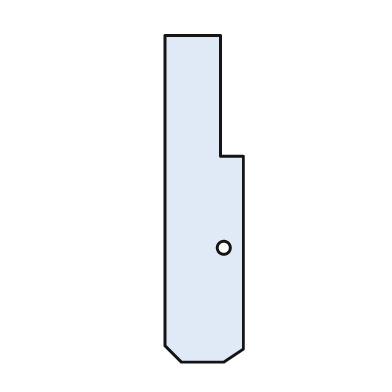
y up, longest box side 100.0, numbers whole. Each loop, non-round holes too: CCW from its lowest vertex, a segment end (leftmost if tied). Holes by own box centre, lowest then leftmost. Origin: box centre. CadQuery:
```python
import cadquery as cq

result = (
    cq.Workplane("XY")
    .moveTo(-7.0, -50.0)
    .lineTo(6.0, -50.0)
    .lineTo(12.0, -46.0)
    .lineTo(12.0, 13.0)
    .lineTo(5.0, 13.0)
    .lineTo(5.0, 50.0)
    .lineTo(-12.0, 50.0)
    .lineTo(-12.0, -45.0)
    .close()
    .moveTo(6.0, -15.0)
    .circle(2.0)
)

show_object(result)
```